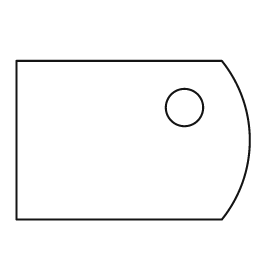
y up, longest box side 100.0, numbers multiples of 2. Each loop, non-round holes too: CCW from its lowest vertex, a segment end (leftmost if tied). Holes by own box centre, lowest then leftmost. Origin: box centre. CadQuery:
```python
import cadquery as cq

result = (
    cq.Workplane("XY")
    .moveTo(-50.0, -34.0)
    .lineTo(38.0, -34.0)
    .threePointArc((50.0, 0.0), (38.0, 34.0))
    .lineTo(-50.0, 34.0)
    .close()
    .moveTo(22.0, 14.0)
    .circle(8.0)
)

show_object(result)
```